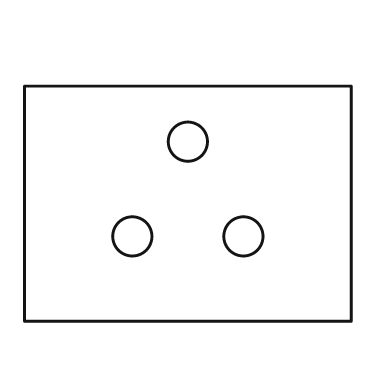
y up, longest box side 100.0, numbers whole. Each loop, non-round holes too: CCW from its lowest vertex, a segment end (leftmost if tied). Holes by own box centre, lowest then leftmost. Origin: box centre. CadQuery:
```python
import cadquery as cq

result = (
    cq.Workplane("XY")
    .moveTo(-50.0, -36.0)
    .lineTo(50.0, -36.0)
    .lineTo(50.0, 36.0)
    .lineTo(-50.0, 36.0)
    .close()
    .moveTo(-17.0, -10.0)
    .circle(6.0)
    .moveTo(17.0, -10.0)
    .circle(6.0)
    .moveTo(0.0, 19.0)
    .circle(6.0)
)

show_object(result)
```